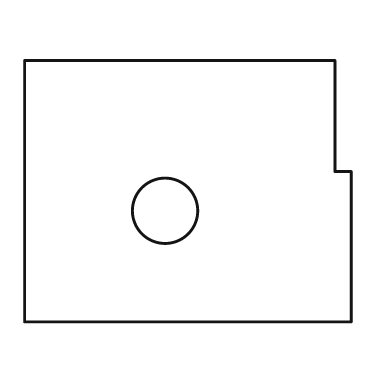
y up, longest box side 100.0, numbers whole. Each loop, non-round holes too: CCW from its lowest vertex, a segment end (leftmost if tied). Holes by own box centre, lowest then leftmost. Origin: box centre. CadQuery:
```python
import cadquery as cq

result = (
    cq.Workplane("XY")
    .moveTo(-50.0, -40.0)
    .lineTo(50.0, -40.0)
    .lineTo(50.0, 6.0)
    .lineTo(45.0, 6.0)
    .lineTo(45.0, 40.0)
    .lineTo(-50.0, 40.0)
    .close()
    .moveTo(-7.0, -6.0)
    .circle(10.0)
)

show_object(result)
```